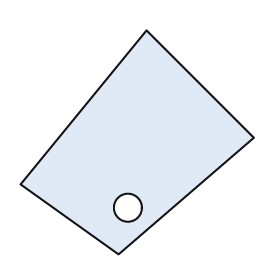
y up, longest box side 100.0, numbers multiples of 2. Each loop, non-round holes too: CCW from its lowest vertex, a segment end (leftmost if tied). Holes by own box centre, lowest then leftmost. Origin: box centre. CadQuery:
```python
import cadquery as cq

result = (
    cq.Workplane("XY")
    .moveTo(-8.0, -48.0)
    .lineTo(50.0, 2.0)
    .lineTo(4.0, 48.0)
    .lineTo(-50.0, -18.0)
    .close()
    .moveTo(-4.0, -28.0)
    .circle(6.0)
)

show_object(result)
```